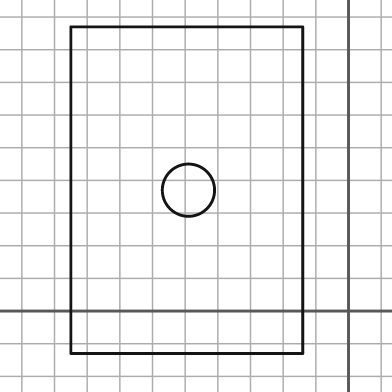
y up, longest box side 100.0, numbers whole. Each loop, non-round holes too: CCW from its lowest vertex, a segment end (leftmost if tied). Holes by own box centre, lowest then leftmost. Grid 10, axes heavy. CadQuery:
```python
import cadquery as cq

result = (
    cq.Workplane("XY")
    .moveTo(-85.0, -13.0)
    .lineTo(-14.0, -13.0)
    .lineTo(-14.0, 87.0)
    .lineTo(-85.0, 87.0)
    .close()
    .moveTo(-49.0, 37.0)
    .circle(8.0)
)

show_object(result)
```